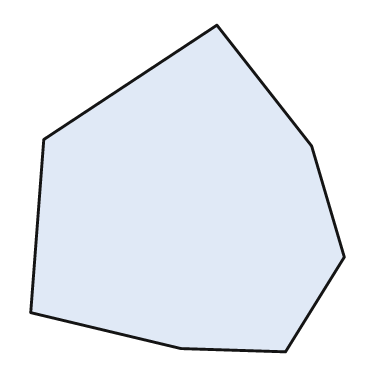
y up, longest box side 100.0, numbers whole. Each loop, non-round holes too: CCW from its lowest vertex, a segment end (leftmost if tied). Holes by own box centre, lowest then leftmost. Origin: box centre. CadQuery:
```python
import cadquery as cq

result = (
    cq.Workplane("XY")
    .moveTo(30.0, -50.0)
    .lineTo(48.0, -21.0)
    .lineTo(38.0, 13.0)
    .lineTo(9.0, 50.0)
    .lineTo(-44.0, 15.0)
    .lineTo(-48.0, -38.0)
    .lineTo(-2.0, -49.0)
    .close()
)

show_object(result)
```